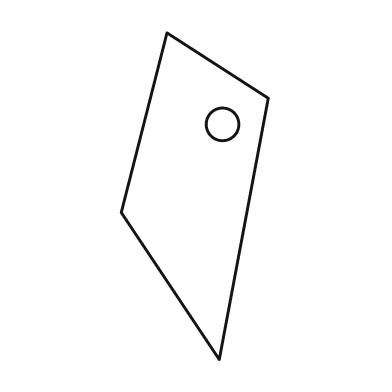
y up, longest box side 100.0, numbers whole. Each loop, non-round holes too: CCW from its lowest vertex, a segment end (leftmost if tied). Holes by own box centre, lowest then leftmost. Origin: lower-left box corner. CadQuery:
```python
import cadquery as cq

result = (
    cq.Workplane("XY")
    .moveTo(30.0, 0.0)
    .lineTo(45.0, 80.0)
    .lineTo(14.0, 100.0)
    .lineTo(0.0, 45.0)
    .close()
    .moveTo(31.0, 72.0)
    .circle(5.0)
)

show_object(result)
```